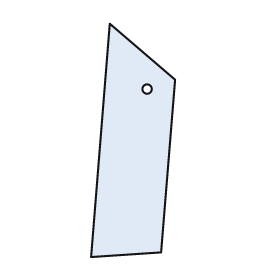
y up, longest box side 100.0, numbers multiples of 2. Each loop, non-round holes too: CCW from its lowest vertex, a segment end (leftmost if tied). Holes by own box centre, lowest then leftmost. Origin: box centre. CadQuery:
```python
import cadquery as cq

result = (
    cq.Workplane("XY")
    .moveTo(-18.0, -50.0)
    .lineTo(12.0, -48.0)
    .lineTo(18.0, 26.0)
    .lineTo(-10.0, 50.0)
    .close()
    .moveTo(6.0, 22.0)
    .circle(2.0)
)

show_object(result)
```